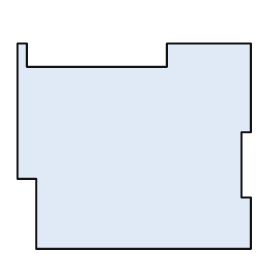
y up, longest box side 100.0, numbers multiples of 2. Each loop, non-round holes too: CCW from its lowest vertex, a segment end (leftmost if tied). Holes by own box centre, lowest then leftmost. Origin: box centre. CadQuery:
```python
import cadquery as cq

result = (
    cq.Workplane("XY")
    .moveTo(-42.0, -44.0)
    .lineTo(50.0, -44.0)
    .lineTo(50.0, -22.0)
    .lineTo(46.0, -22.0)
    .lineTo(46.0, 6.0)
    .lineTo(50.0, 6.0)
    .lineTo(50.0, 44.0)
    .lineTo(14.0, 44.0)
    .lineTo(14.0, 34.0)
    .lineTo(-46.0, 34.0)
    .lineTo(-46.0, 44.0)
    .lineTo(-50.0, 44.0)
    .lineTo(-50.0, -14.0)
    .lineTo(-42.0, -14.0)
    .close()
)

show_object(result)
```